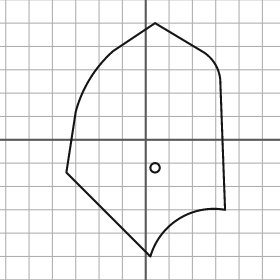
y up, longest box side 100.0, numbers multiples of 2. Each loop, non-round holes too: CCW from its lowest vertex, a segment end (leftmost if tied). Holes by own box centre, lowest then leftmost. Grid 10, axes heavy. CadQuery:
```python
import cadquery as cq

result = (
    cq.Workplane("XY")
    .moveTo(2.0, -50.0)
    .threePointArc((14.0, -34.0), (34.0, -30.0))
    .lineTo(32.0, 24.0)
    .threePointArc((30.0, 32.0), (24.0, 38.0))
    .lineTo(4.0, 50.0)
    .lineTo(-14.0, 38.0)
    .threePointArc((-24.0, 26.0), (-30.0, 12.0))
    .lineTo(-34.0, -14.0)
    .close()
    .moveTo(4.0, -12.0)
    .circle(2.0)
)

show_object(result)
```